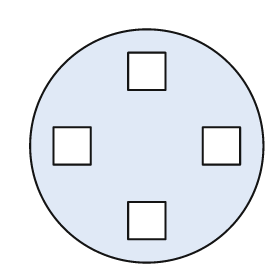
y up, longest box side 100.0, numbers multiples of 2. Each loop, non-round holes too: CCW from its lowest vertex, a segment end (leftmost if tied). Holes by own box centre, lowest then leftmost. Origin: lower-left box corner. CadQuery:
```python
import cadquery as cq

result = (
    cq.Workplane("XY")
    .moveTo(50.0, 50.0)
    .circle(50.0)
    .moveTo(42.0, 10.0)
    .lineTo(58.0, 10.0)
    .lineTo(58.0, 26.0)
    .lineTo(42.0, 26.0)
    .close()
    .moveTo(10.0, 42.0)
    .lineTo(26.0, 42.0)
    .lineTo(26.0, 58.0)
    .lineTo(10.0, 58.0)
    .close()
    .moveTo(74.0, 42.0)
    .lineTo(90.0, 42.0)
    .lineTo(90.0, 58.0)
    .lineTo(74.0, 58.0)
    .close()
    .moveTo(42.0, 74.0)
    .lineTo(58.0, 74.0)
    .lineTo(58.0, 90.0)
    .lineTo(42.0, 90.0)
    .close()
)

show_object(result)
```